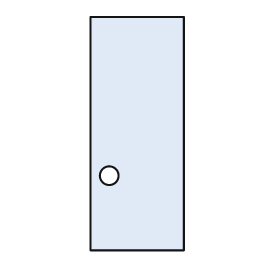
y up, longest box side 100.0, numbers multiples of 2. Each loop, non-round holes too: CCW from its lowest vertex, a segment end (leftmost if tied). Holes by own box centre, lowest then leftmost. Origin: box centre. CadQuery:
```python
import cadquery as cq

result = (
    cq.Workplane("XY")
    .moveTo(-20.0, -50.0)
    .lineTo(20.0, -50.0)
    .lineTo(20.0, 50.0)
    .lineTo(-20.0, 50.0)
    .close()
    .moveTo(-12.0, -18.0)
    .circle(4.0)
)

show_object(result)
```